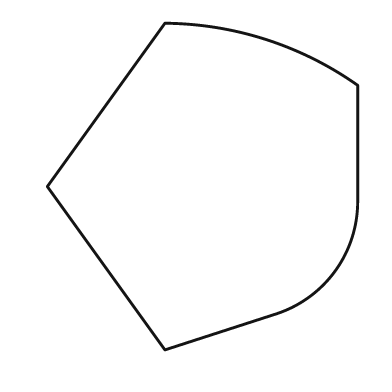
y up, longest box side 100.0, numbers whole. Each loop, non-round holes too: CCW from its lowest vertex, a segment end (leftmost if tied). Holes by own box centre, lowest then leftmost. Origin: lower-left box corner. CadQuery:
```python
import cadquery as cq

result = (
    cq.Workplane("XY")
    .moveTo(36.0, 0.0)
    .lineTo(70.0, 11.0)
    .threePointArc((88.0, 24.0), (95.0, 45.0))
    .lineTo(95.0, 81.0)
    .threePointArc((67.0, 95.0), (36.0, 100.0))
    .lineTo(0.0, 50.0)
    .close()
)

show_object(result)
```